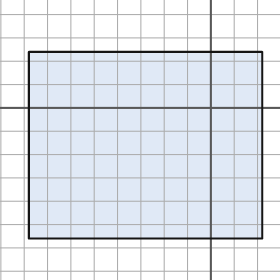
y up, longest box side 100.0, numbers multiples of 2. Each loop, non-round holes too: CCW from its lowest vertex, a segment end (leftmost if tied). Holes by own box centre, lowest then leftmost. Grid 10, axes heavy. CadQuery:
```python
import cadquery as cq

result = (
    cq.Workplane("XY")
    .moveTo(-78.0, -56.0)
    .lineTo(22.0, -56.0)
    .lineTo(22.0, 24.0)
    .lineTo(-78.0, 24.0)
    .close()
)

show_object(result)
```